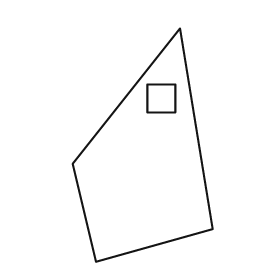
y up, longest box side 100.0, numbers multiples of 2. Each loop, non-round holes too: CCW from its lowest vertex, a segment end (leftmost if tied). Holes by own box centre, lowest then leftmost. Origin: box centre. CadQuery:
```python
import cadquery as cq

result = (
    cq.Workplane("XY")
    .moveTo(-20.0, -50.0)
    .lineTo(30.0, -36.0)
    .lineTo(16.0, 50.0)
    .lineTo(-30.0, -8.0)
    .close()
    .moveTo(2.0, 14.0)
    .lineTo(14.0, 14.0)
    .lineTo(14.0, 26.0)
    .lineTo(2.0, 26.0)
    .close()
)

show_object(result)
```